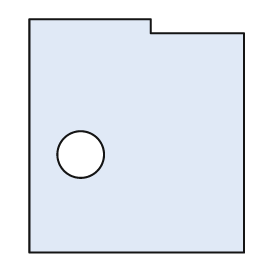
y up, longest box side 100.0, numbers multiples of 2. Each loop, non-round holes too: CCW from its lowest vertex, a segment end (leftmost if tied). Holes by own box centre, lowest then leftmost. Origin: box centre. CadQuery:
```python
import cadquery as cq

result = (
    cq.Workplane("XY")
    .moveTo(-46.0, -50.0)
    .lineTo(46.0, -50.0)
    .lineTo(46.0, 44.0)
    .lineTo(6.0, 44.0)
    .lineTo(6.0, 50.0)
    .lineTo(-46.0, 50.0)
    .close()
    .moveTo(-24.0, -8.0)
    .circle(10.0)
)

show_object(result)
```